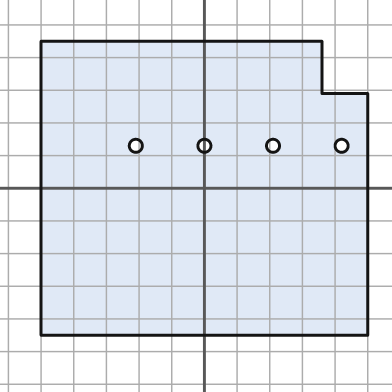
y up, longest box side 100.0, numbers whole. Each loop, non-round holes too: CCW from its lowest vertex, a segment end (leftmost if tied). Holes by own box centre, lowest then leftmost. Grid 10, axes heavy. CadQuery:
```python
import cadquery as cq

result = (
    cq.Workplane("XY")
    .moveTo(-50.0, -45.0)
    .lineTo(50.0, -45.0)
    .lineTo(50.0, 29.0)
    .lineTo(36.0, 29.0)
    .lineTo(36.0, 45.0)
    .lineTo(-50.0, 45.0)
    .close()
    .moveTo(-21.0, 13.0)
    .circle(2.0)
    .moveTo(0.0, 13.0)
    .circle(2.0)
    .moveTo(21.0, 13.0)
    .circle(2.0)
    .moveTo(42.0, 13.0)
    .circle(2.0)
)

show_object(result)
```